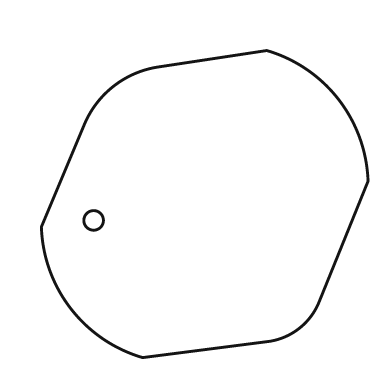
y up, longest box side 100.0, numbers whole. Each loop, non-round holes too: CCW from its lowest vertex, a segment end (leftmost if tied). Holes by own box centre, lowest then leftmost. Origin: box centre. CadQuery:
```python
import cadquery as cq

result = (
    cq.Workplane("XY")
    .moveTo(-19.0, -47.0)
    .lineTo(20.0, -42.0)
    .threePointArc((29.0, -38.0), (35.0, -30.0))
    .lineTo(50.0, 7.0)
    .threePointArc((41.0, 32.0), (19.0, 47.0))
    .lineTo(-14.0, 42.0)
    .threePointArc((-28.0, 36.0), (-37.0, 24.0))
    .lineTo(-50.0, -7.0)
    .threePointArc((-41.0, -32.0), (-19.0, -47.0))
    .close()
    .moveTo(-34.0, -5.0)
    .circle(3.0)
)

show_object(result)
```